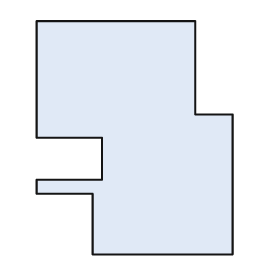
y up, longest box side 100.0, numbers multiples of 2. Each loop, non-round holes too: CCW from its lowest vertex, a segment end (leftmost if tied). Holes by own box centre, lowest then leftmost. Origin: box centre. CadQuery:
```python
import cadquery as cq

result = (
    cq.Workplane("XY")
    .moveTo(-18.0, -50.0)
    .lineTo(42.0, -50.0)
    .lineTo(42.0, 10.0)
    .lineTo(26.0, 10.0)
    .lineTo(26.0, 50.0)
    .lineTo(-42.0, 50.0)
    .lineTo(-42.0, 0.0)
    .lineTo(-14.0, 0.0)
    .lineTo(-14.0, -18.0)
    .lineTo(-42.0, -18.0)
    .lineTo(-42.0, -24.0)
    .lineTo(-18.0, -24.0)
    .close()
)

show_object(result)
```